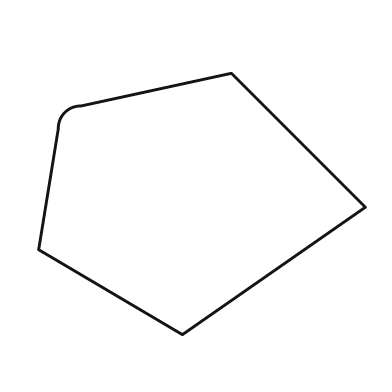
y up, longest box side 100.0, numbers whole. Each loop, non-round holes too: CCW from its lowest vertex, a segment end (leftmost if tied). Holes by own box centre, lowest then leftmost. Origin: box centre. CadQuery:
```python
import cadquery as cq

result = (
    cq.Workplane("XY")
    .moveTo(-6.0, -40.0)
    .lineTo(50.0, -1.0)
    .lineTo(9.0, 40.0)
    .lineTo(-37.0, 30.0)
    .threePointArc((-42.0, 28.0), (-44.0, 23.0))
    .lineTo(-50.0, -14.0)
    .close()
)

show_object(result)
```